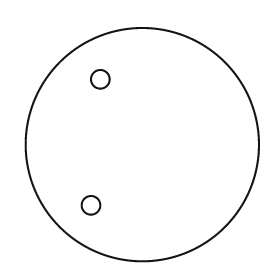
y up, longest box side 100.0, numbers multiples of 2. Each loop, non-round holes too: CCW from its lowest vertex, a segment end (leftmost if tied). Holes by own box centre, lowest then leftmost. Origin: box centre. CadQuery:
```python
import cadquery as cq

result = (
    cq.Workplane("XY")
    .moveTo(0.0, 0.0)
    .circle(50.0)
    .moveTo(-22.0, -26.0)
    .circle(4.0)
    .moveTo(-18.0, 28.0)
    .circle(4.0)
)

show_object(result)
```